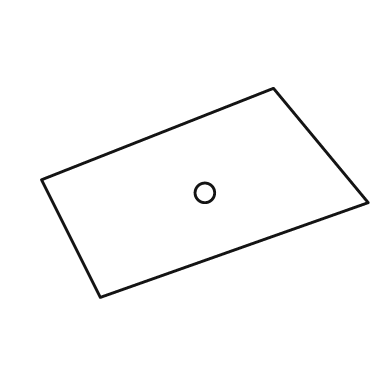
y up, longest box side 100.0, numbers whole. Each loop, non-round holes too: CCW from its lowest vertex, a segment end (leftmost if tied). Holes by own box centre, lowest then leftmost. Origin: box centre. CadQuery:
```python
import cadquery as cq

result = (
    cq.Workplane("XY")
    .moveTo(-32.0, -32.0)
    .lineTo(50.0, -3.0)
    .lineTo(21.0, 32.0)
    .lineTo(-50.0, 4.0)
    .close()
    .moveTo(0.0, 0.0)
    .circle(3.0)
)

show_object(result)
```